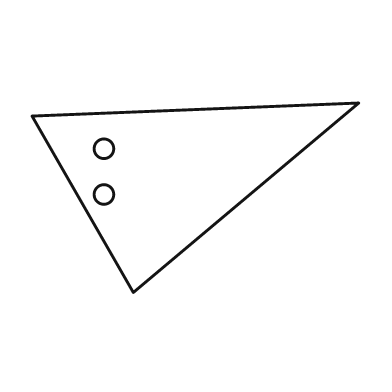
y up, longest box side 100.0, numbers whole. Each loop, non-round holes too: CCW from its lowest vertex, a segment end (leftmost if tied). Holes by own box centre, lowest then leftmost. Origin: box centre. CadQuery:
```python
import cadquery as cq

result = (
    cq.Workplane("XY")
    .moveTo(-19.0, -29.0)
    .lineTo(50.0, 29.0)
    .lineTo(-50.0, 25.0)
    .close()
    .moveTo(-28.0, 1.0)
    .circle(3.0)
    .moveTo(-28.0, 15.0)
    .circle(3.0)
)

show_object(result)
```